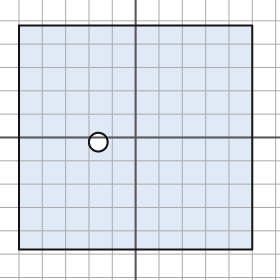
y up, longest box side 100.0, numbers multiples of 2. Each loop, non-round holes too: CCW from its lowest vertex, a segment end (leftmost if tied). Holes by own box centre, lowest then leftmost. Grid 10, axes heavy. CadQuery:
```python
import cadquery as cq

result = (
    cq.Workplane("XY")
    .moveTo(-50.0, -48.0)
    .lineTo(50.0, -48.0)
    .lineTo(50.0, 48.0)
    .lineTo(-50.0, 48.0)
    .close()
    .moveTo(-16.0, -2.0)
    .circle(4.0)
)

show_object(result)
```